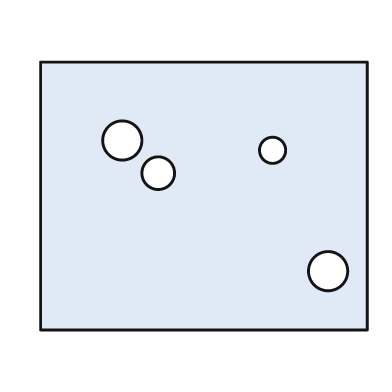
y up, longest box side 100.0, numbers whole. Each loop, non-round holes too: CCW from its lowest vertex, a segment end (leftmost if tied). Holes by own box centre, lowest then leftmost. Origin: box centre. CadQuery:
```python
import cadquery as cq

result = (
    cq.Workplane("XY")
    .moveTo(-50.0, -41.0)
    .lineTo(50.0, -41.0)
    .lineTo(50.0, 41.0)
    .lineTo(-50.0, 41.0)
    .close()
    .moveTo(38.0, -23.0)
    .circle(6.0)
    .moveTo(-14.0, 7.0)
    .circle(5.0)
    .moveTo(21.0, 14.0)
    .circle(4.0)
    .moveTo(-25.0, 17.0)
    .circle(6.0)
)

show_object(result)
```